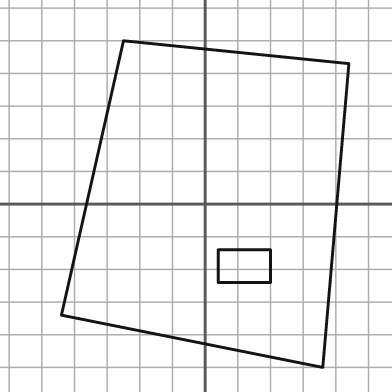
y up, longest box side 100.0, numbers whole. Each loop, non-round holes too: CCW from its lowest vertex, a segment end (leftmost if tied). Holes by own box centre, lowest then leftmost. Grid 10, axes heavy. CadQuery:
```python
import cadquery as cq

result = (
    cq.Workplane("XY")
    .moveTo(36.0, -50.0)
    .lineTo(44.0, 43.0)
    .lineTo(-25.0, 50.0)
    .lineTo(-44.0, -34.0)
    .close()
    .moveTo(4.0, -24.0)
    .lineTo(20.0, -24.0)
    .lineTo(20.0, -14.0)
    .lineTo(4.0, -14.0)
    .close()
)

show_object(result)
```